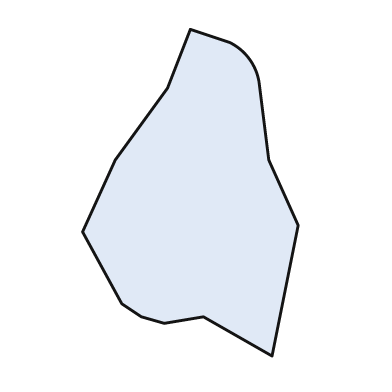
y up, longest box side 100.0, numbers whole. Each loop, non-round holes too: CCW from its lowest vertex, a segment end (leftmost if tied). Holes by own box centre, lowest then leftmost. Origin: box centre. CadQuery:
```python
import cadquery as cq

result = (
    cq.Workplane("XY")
    .moveTo(25.0, -50.0)
    .lineTo(33.0, -10.0)
    .lineTo(24.0, 10.0)
    .lineTo(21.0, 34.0)
    .threePointArc((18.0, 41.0), (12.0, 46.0))
    .lineTo(0.0, 50.0)
    .lineTo(-7.0, 32.0)
    .lineTo(-23.0, 10.0)
    .lineTo(-33.0, -12.0)
    .lineTo(-21.0, -34.0)
    .lineTo(-15.0, -38.0)
    .lineTo(-8.0, -40.0)
    .lineTo(4.0, -38.0)
    .close()
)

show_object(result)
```